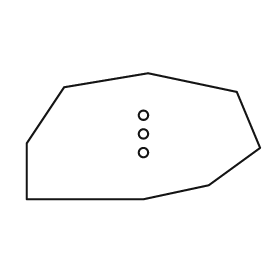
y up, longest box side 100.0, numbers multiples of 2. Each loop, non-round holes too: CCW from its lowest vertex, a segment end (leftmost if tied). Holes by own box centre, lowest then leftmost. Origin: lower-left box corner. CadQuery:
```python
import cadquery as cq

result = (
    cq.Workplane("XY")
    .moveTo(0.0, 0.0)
    .lineTo(50.0, 0.0)
    .lineTo(78.0, 6.0)
    .lineTo(100.0, 22.0)
    .lineTo(90.0, 46.0)
    .lineTo(52.0, 54.0)
    .lineTo(16.0, 48.0)
    .lineTo(0.0, 24.0)
    .close()
    .moveTo(50.0, 20.0)
    .circle(2.0)
    .moveTo(50.0, 28.0)
    .circle(2.0)
    .moveTo(50.0, 36.0)
    .circle(2.0)
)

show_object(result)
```